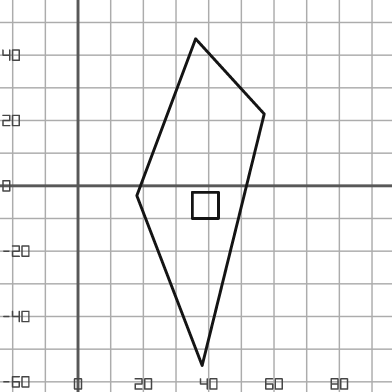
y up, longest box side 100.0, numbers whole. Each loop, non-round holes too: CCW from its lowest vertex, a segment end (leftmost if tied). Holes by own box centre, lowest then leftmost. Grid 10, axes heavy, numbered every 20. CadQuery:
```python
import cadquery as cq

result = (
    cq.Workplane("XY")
    .moveTo(38.0, -55.0)
    .lineTo(57.0, 22.0)
    .lineTo(36.0, 45.0)
    .lineTo(18.0, -3.0)
    .close()
    .moveTo(35.0, -10.0)
    .lineTo(43.0, -10.0)
    .lineTo(43.0, -2.0)
    .lineTo(35.0, -2.0)
    .close()
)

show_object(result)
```